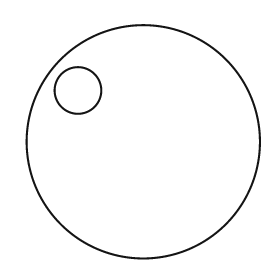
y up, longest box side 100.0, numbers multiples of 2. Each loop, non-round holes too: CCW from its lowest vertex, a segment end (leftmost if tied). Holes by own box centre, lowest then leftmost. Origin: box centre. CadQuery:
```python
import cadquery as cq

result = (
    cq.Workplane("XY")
    .moveTo(0.0, 0.0)
    .circle(50.0)
    .moveTo(-28.0, 22.0)
    .circle(10.0)
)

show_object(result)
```